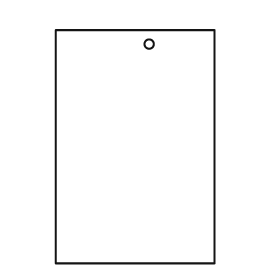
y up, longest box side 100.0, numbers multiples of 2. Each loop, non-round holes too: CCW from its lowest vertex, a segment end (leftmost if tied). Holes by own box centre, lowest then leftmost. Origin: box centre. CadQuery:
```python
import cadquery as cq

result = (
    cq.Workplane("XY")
    .moveTo(-34.0, -50.0)
    .lineTo(34.0, -50.0)
    .lineTo(34.0, 50.0)
    .lineTo(-34.0, 50.0)
    .close()
    .moveTo(6.0, 44.0)
    .circle(2.0)
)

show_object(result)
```